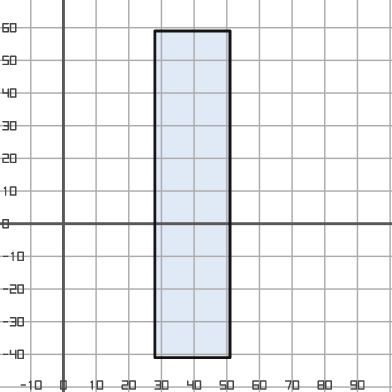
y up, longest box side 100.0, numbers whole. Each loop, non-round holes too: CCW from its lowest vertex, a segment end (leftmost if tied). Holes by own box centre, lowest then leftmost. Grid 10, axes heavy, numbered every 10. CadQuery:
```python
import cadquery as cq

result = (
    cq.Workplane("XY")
    .moveTo(28.0, -41.0)
    .lineTo(51.0, -41.0)
    .lineTo(51.0, 59.0)
    .lineTo(28.0, 59.0)
    .close()
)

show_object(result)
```